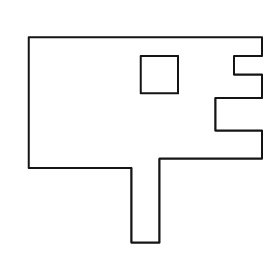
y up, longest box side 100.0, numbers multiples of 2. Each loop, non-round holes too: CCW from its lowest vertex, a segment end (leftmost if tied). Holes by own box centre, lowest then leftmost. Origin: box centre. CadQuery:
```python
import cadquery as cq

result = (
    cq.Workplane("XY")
    .moveTo(-6.0, -44.0)
    .lineTo(6.0, -44.0)
    .lineTo(6.0, -8.0)
    .lineTo(50.0, -8.0)
    .lineTo(50.0, 4.0)
    .lineTo(30.0, 4.0)
    .lineTo(30.0, 18.0)
    .lineTo(50.0, 18.0)
    .lineTo(50.0, 28.0)
    .lineTo(38.0, 28.0)
    .lineTo(38.0, 36.0)
    .lineTo(50.0, 36.0)
    .lineTo(50.0, 44.0)
    .lineTo(-50.0, 44.0)
    .lineTo(-50.0, -12.0)
    .lineTo(-6.0, -12.0)
    .close()
    .moveTo(-2.0, 20.0)
    .lineTo(14.0, 20.0)
    .lineTo(14.0, 36.0)
    .lineTo(-2.0, 36.0)
    .close()
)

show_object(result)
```